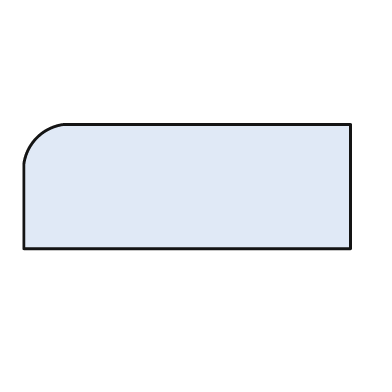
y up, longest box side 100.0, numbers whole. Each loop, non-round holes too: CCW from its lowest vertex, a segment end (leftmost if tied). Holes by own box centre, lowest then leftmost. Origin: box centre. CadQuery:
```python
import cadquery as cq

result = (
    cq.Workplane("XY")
    .moveTo(-50.0, -19.0)
    .lineTo(50.0, -19.0)
    .lineTo(50.0, 19.0)
    .lineTo(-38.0, 19.0)
    .threePointArc((-46.0, 15.0), (-50.0, 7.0))
    .close()
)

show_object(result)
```